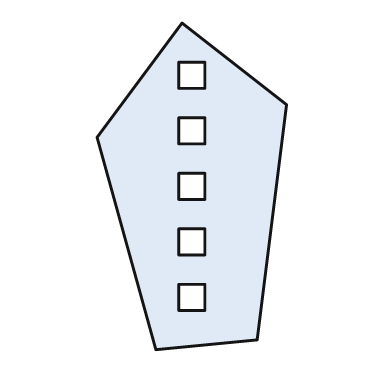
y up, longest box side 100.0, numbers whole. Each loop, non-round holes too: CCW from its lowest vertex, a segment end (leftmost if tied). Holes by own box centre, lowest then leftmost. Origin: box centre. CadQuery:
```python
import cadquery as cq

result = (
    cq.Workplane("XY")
    .moveTo(-11.0, -50.0)
    .lineTo(20.0, -47.0)
    .lineTo(29.0, 25.0)
    .lineTo(-3.0, 50.0)
    .lineTo(-29.0, 15.0)
    .close()
    .moveTo(-4.0, -38.0)
    .lineTo(4.0, -38.0)
    .lineTo(4.0, -30.0)
    .lineTo(-4.0, -30.0)
    .close()
    .moveTo(-4.0, -21.0)
    .lineTo(4.0, -21.0)
    .lineTo(4.0, -13.0)
    .lineTo(-4.0, -13.0)
    .close()
    .moveTo(-4.0, -4.0)
    .lineTo(4.0, -4.0)
    .lineTo(4.0, 4.0)
    .lineTo(-4.0, 4.0)
    .close()
    .moveTo(-4.0, 13.0)
    .lineTo(4.0, 13.0)
    .lineTo(4.0, 21.0)
    .lineTo(-4.0, 21.0)
    .close()
    .moveTo(-4.0, 30.0)
    .lineTo(4.0, 30.0)
    .lineTo(4.0, 38.0)
    .lineTo(-4.0, 38.0)
    .close()
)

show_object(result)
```